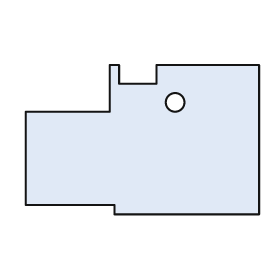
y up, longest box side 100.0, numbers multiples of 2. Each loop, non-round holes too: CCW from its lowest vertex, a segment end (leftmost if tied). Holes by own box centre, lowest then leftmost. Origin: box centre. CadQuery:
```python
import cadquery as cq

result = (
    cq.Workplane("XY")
    .moveTo(-12.0, -32.0)
    .lineTo(50.0, -32.0)
    .lineTo(50.0, 32.0)
    .lineTo(6.0, 32.0)
    .lineTo(6.0, 24.0)
    .lineTo(-10.0, 24.0)
    .lineTo(-10.0, 32.0)
    .lineTo(-14.0, 32.0)
    .lineTo(-14.0, 12.0)
    .lineTo(-50.0, 12.0)
    .lineTo(-50.0, -28.0)
    .lineTo(-12.0, -28.0)
    .close()
    .moveTo(14.0, 16.0)
    .circle(4.0)
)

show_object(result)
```